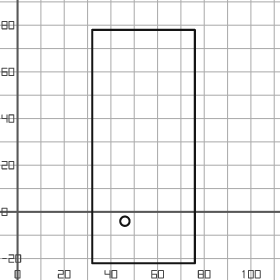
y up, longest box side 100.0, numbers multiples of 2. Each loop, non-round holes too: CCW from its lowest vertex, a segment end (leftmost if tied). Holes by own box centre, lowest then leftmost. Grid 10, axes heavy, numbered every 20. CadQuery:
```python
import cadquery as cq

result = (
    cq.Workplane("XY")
    .moveTo(32.0, -22.0)
    .lineTo(76.0, -22.0)
    .lineTo(76.0, 78.0)
    .lineTo(32.0, 78.0)
    .close()
    .moveTo(46.0, -4.0)
    .circle(2.0)
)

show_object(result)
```